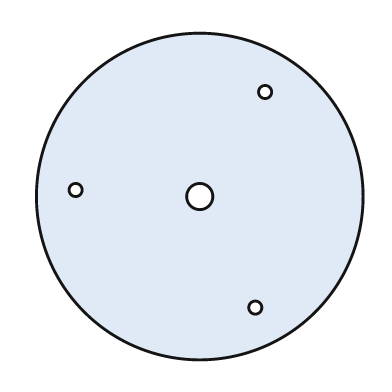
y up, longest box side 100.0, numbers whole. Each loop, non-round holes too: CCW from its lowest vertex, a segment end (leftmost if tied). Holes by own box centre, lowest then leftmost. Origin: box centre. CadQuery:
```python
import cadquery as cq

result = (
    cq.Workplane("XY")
    .moveTo(0.0, 0.0)
    .circle(50.0)
    .moveTo(17.0, -34.0)
    .circle(2.0)
    .moveTo(0.0, 0.0)
    .circle(4.0)
    .moveTo(-38.0, 2.0)
    .circle(2.0)
    .moveTo(20.0, 32.0)
    .circle(2.0)
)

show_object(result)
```